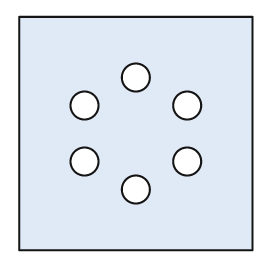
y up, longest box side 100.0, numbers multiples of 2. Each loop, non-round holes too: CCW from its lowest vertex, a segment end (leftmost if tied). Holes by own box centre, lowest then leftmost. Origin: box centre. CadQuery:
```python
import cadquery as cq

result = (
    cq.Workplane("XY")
    .moveTo(-50.0, -50.0)
    .lineTo(50.0, -50.0)
    .lineTo(50.0, 50.0)
    .lineTo(-50.0, 50.0)
    .close()
    .moveTo(0.0, -24.0)
    .circle(6.0)
    .moveTo(-22.0, -12.0)
    .circle(6.0)
    .moveTo(22.0, -12.0)
    .circle(6.0)
    .moveTo(-22.0, 12.0)
    .circle(6.0)
    .moveTo(22.0, 12.0)
    .circle(6.0)
    .moveTo(0.0, 24.0)
    .circle(6.0)
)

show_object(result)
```